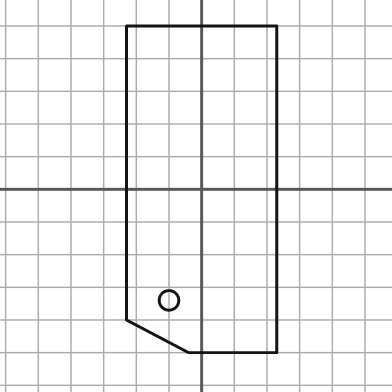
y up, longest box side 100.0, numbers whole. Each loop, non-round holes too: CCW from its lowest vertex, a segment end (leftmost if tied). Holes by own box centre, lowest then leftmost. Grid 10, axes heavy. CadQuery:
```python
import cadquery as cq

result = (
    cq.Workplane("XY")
    .moveTo(-4.0, -50.0)
    .lineTo(23.0, -50.0)
    .lineTo(23.0, 50.0)
    .lineTo(-23.0, 50.0)
    .lineTo(-23.0, -40.0)
    .close()
    .moveTo(-10.0, -34.0)
    .circle(3.0)
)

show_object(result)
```